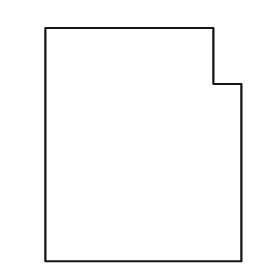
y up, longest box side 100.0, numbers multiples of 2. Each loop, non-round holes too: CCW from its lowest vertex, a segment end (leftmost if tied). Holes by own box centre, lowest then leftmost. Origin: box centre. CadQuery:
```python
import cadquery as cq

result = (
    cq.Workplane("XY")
    .moveTo(-42.0, -50.0)
    .lineTo(42.0, -50.0)
    .lineTo(42.0, 26.0)
    .lineTo(30.0, 26.0)
    .lineTo(30.0, 50.0)
    .lineTo(-42.0, 50.0)
    .close()
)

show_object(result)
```